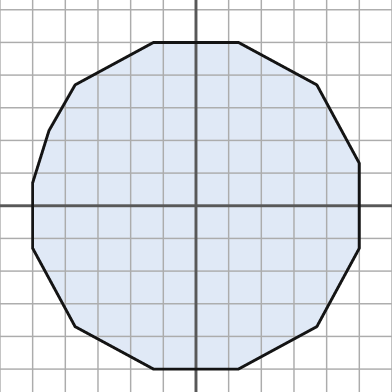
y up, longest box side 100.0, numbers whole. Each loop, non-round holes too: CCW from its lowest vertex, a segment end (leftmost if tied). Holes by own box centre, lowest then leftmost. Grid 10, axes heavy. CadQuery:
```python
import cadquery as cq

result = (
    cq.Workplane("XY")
    .moveTo(-13.0, -50.0)
    .lineTo(13.0, -50.0)
    .lineTo(37.0, -37.0)
    .lineTo(50.0, -13.0)
    .lineTo(50.0, 13.0)
    .lineTo(37.0, 37.0)
    .lineTo(13.0, 50.0)
    .lineTo(-13.0, 50.0)
    .lineTo(-37.0, 37.0)
    .lineTo(-45.0, 23.0)
    .lineTo(-50.0, 7.0)
    .lineTo(-50.0, -13.0)
    .lineTo(-37.0, -37.0)
    .close()
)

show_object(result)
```